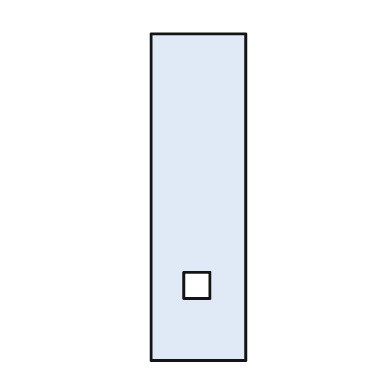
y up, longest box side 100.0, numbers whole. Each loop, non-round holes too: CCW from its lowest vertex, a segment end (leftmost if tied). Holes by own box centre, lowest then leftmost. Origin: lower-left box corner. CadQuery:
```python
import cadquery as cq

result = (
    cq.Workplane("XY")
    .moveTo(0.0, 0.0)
    .lineTo(29.0, 0.0)
    .lineTo(29.0, 100.0)
    .lineTo(0.0, 100.0)
    .close()
    .moveTo(10.0, 19.0)
    .lineTo(18.0, 19.0)
    .lineTo(18.0, 27.0)
    .lineTo(10.0, 27.0)
    .close()
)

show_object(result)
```